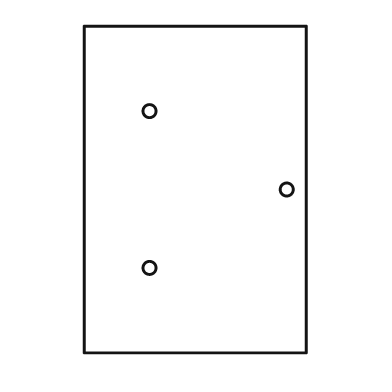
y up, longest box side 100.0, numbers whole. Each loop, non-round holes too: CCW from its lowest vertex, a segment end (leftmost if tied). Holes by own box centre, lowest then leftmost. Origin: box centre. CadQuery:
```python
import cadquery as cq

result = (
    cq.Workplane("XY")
    .moveTo(-34.0, -50.0)
    .lineTo(34.0, -50.0)
    .lineTo(34.0, 50.0)
    .lineTo(-34.0, 50.0)
    .close()
    .moveTo(-14.0, -24.0)
    .circle(2.0)
    .moveTo(28.0, 0.0)
    .circle(2.0)
    .moveTo(-14.0, 24.0)
    .circle(2.0)
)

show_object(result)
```